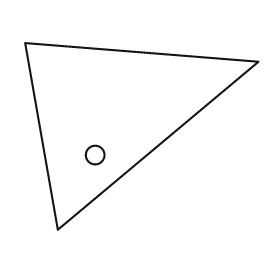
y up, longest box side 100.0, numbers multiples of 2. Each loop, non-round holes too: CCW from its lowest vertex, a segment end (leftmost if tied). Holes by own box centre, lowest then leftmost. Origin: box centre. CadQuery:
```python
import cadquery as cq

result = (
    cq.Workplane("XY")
    .moveTo(-36.0, -40.0)
    .lineTo(50.0, 32.0)
    .lineTo(-50.0, 40.0)
    .close()
    .moveTo(-20.0, -8.0)
    .circle(4.0)
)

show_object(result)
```